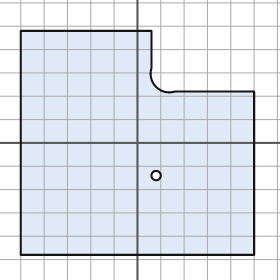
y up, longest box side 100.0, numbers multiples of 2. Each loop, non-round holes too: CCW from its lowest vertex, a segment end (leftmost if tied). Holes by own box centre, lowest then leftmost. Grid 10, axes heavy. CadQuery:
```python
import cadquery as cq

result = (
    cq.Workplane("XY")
    .moveTo(-50.0, -48.0)
    .lineTo(50.0, -48.0)
    .lineTo(50.0, 22.0)
    .lineTo(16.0, 22.0)
    .threePointArc((8.0, 24.0), (6.0, 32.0))
    .lineTo(6.0, 48.0)
    .lineTo(-50.0, 48.0)
    .close()
    .moveTo(8.0, -14.0)
    .circle(2.0)
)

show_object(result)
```